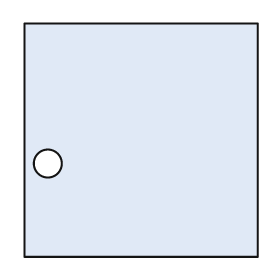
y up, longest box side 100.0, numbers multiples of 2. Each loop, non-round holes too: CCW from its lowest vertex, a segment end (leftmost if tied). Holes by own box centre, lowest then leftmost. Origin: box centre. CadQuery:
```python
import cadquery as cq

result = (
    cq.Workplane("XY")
    .moveTo(-50.0, -50.0)
    .lineTo(50.0, -50.0)
    .lineTo(50.0, 50.0)
    .lineTo(-50.0, 50.0)
    .close()
    .moveTo(-40.0, -10.0)
    .circle(6.0)
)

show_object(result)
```